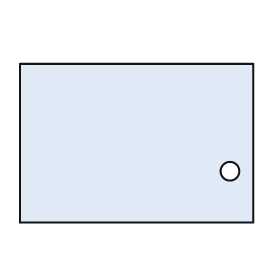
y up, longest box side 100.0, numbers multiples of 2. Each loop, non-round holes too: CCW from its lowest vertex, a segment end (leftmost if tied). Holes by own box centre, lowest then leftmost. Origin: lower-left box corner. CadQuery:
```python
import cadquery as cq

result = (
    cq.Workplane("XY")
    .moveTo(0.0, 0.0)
    .lineTo(100.0, 0.0)
    .lineTo(100.0, 68.0)
    .lineTo(0.0, 68.0)
    .close()
    .moveTo(90.0, 22.0)
    .circle(4.0)
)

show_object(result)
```